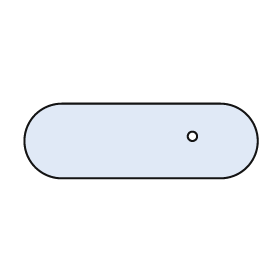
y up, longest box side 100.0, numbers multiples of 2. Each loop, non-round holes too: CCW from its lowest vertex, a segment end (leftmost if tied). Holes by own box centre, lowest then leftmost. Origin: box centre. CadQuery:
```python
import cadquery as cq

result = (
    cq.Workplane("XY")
    .moveTo(-34.0, -16.0)
    .lineTo(34.0, -16.0)
    .threePointArc((50.0, 0.0), (34.0, 16.0))
    .lineTo(-34.0, 16.0)
    .threePointArc((-50.0, 0.0), (-34.0, -16.0))
    .close()
    .moveTo(22.0, 2.0)
    .circle(2.0)
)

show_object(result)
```